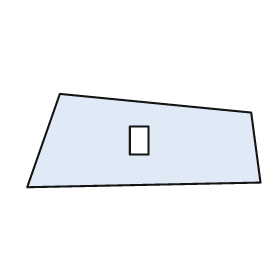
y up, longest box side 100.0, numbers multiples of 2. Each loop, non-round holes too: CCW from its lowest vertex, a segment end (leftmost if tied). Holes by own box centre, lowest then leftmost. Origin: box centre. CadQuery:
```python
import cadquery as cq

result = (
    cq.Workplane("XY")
    .moveTo(-50.0, -20.0)
    .lineTo(50.0, -18.0)
    .lineTo(46.0, 12.0)
    .lineTo(-36.0, 20.0)
    .close()
    .moveTo(-6.0, -6.0)
    .lineTo(2.0, -6.0)
    .lineTo(2.0, 6.0)
    .lineTo(-6.0, 6.0)
    .close()
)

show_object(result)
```